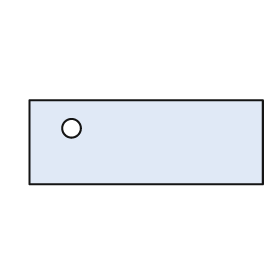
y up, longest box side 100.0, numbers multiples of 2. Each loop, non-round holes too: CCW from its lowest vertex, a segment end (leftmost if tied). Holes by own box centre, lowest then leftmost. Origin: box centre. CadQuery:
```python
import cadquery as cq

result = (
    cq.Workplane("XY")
    .moveTo(-50.0, -18.0)
    .lineTo(50.0, -18.0)
    .lineTo(50.0, 18.0)
    .lineTo(-50.0, 18.0)
    .close()
    .moveTo(-32.0, 6.0)
    .circle(4.0)
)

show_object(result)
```